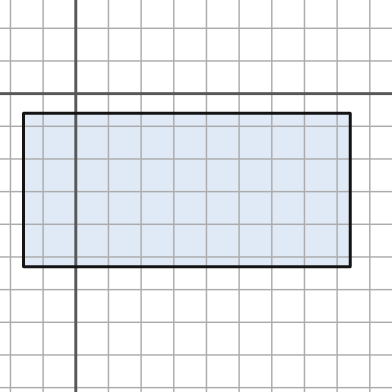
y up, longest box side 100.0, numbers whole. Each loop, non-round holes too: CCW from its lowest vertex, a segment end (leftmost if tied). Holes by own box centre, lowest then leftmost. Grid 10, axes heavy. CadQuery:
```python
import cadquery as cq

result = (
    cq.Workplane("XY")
    .moveTo(-16.0, -53.0)
    .lineTo(84.0, -53.0)
    .lineTo(84.0, -6.0)
    .lineTo(-16.0, -6.0)
    .close()
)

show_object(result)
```